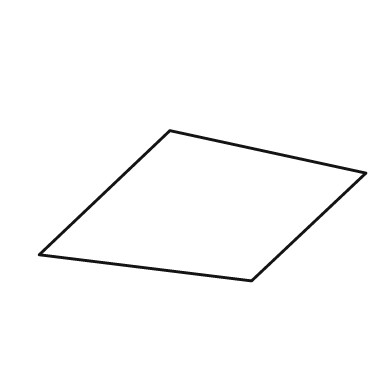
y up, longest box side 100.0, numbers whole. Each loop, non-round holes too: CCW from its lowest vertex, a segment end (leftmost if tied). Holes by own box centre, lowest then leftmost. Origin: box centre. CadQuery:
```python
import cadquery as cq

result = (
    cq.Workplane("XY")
    .moveTo(15.0, -23.0)
    .lineTo(50.0, 10.0)
    .lineTo(-10.0, 23.0)
    .lineTo(-50.0, -15.0)
    .close()
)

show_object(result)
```